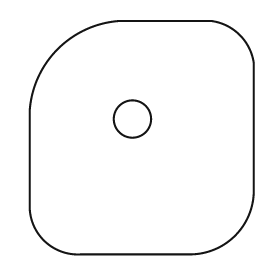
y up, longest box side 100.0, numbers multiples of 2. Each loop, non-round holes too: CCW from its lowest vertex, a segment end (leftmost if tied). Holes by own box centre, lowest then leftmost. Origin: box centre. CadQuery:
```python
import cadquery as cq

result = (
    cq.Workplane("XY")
    .moveTo(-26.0, -50.0)
    .lineTo(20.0, -50.0)
    .threePointArc((40.0, -42.0), (48.0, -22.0))
    .lineTo(48.0, 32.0)
    .threePointArc((42.0, 44.0), (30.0, 50.0))
    .lineTo(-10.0, 50.0)
    .threePointArc((-36.0, 38.0), (-48.0, 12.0))
    .lineTo(-48.0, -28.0)
    .threePointArc((-42.0, -44.0), (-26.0, -50.0))
    .close()
    .moveTo(-4.0, 8.0)
    .circle(8.0)
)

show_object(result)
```